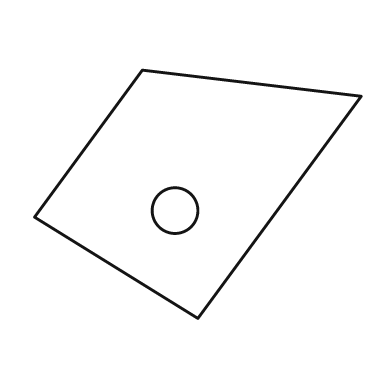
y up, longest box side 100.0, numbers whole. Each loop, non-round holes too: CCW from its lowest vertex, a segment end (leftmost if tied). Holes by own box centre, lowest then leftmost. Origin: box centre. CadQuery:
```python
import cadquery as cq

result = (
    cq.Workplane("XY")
    .moveTo(0.0, -38.0)
    .lineTo(50.0, 30.0)
    .lineTo(-17.0, 38.0)
    .lineTo(-50.0, -7.0)
    .close()
    .moveTo(-7.0, -5.0)
    .circle(7.0)
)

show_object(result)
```